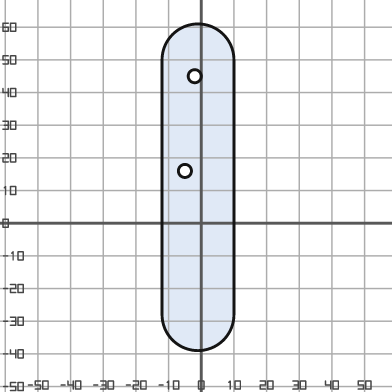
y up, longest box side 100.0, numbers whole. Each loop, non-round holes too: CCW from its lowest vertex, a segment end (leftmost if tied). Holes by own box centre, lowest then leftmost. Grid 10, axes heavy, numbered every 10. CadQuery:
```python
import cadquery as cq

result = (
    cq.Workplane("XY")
    .moveTo(-12.0, -28.0)
    .threePointArc((-1.0, -39.0), (10.0, -28.0))
    .lineTo(10.0, 50.0)
    .threePointArc((-1.0, 61.0), (-12.0, 50.0))
    .close()
    .moveTo(-5.0, 16.0)
    .circle(2.0)
    .moveTo(-2.0, 45.0)
    .circle(2.0)
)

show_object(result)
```